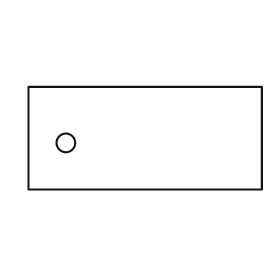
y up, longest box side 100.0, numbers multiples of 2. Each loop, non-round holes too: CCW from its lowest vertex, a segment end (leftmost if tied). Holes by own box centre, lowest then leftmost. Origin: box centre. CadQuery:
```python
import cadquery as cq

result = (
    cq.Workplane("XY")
    .moveTo(-50.0, -22.0)
    .lineTo(50.0, -22.0)
    .lineTo(50.0, 22.0)
    .lineTo(-50.0, 22.0)
    .close()
    .moveTo(-34.0, -2.0)
    .circle(4.0)
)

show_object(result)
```